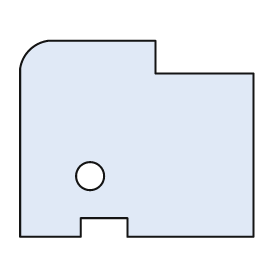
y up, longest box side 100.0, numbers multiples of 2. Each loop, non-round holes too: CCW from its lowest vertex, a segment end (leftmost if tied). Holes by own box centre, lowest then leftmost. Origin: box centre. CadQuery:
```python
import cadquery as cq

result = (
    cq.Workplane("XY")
    .moveTo(-50.0, -42.0)
    .lineTo(-24.0, -42.0)
    .lineTo(-24.0, -34.0)
    .lineTo(-4.0, -34.0)
    .lineTo(-4.0, -42.0)
    .lineTo(50.0, -42.0)
    .lineTo(50.0, 28.0)
    .lineTo(8.0, 28.0)
    .lineTo(8.0, 42.0)
    .lineTo(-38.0, 42.0)
    .threePointArc((-46.0, 38.0), (-50.0, 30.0))
    .close()
    .moveTo(-20.0, -16.0)
    .circle(6.0)
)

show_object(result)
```